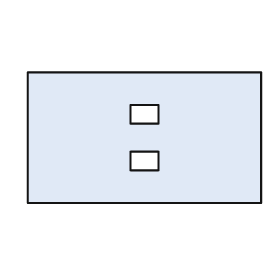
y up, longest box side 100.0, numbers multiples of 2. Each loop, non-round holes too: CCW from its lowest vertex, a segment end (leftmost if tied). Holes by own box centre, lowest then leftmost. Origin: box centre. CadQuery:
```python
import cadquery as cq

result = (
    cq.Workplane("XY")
    .moveTo(-50.0, -28.0)
    .lineTo(50.0, -28.0)
    .lineTo(50.0, 28.0)
    .lineTo(-50.0, 28.0)
    .close()
    .moveTo(-6.0, -14.0)
    .lineTo(6.0, -14.0)
    .lineTo(6.0, -6.0)
    .lineTo(-6.0, -6.0)
    .close()
    .moveTo(-6.0, 6.0)
    .lineTo(6.0, 6.0)
    .lineTo(6.0, 14.0)
    .lineTo(-6.0, 14.0)
    .close()
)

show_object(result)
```